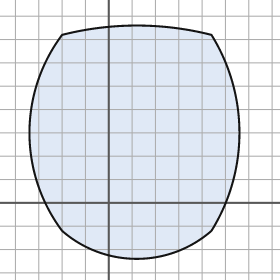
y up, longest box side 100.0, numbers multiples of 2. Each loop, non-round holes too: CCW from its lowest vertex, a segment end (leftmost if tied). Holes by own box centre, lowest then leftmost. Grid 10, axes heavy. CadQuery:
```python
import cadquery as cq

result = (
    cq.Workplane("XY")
    .moveTo(-20.0, -12.0)
    .threePointArc((12.0, -24.0), (44.0, -12.0))
    .threePointArc((56.0, 30.0), (44.0, 72.0))
    .threePointArc((12.0, 76.0), (-20.0, 72.0))
    .threePointArc((-34.0, 30.0), (-20.0, -12.0))
    .close()
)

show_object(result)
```